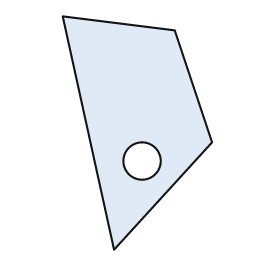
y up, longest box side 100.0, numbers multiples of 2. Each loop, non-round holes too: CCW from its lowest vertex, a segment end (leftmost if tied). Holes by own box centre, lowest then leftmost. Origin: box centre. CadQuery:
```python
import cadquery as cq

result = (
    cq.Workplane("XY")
    .moveTo(-10.0, -50.0)
    .lineTo(32.0, -4.0)
    .lineTo(16.0, 44.0)
    .lineTo(-32.0, 50.0)
    .close()
    .moveTo(2.0, -12.0)
    .circle(8.0)
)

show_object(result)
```